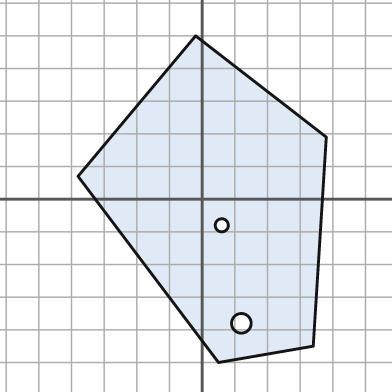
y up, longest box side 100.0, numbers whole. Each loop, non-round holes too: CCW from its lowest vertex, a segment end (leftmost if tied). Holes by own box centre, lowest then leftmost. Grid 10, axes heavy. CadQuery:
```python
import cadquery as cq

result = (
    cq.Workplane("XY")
    .moveTo(5.0, -50.0)
    .lineTo(34.0, -45.0)
    .lineTo(38.0, 19.0)
    .lineTo(-2.0, 50.0)
    .lineTo(-38.0, 7.0)
    .close()
    .moveTo(12.0, -38.0)
    .circle(3.0)
    .moveTo(6.0, -8.0)
    .circle(2.0)
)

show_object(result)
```